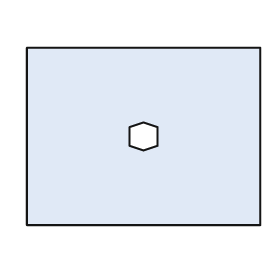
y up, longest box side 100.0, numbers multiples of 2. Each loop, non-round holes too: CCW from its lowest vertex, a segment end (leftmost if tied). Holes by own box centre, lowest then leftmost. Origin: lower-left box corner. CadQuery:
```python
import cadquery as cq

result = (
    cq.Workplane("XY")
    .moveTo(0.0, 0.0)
    .lineTo(100.0, 0.0)
    .lineTo(100.0, 76.0)
    .lineTo(0.0, 76.0)
    .close()
    .moveTo(50.0, 32.0)
    .lineTo(56.0, 34.0)
    .lineTo(56.0, 42.0)
    .lineTo(50.0, 44.0)
    .lineTo(44.0, 42.0)
    .lineTo(44.0, 34.0)
    .close()
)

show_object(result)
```